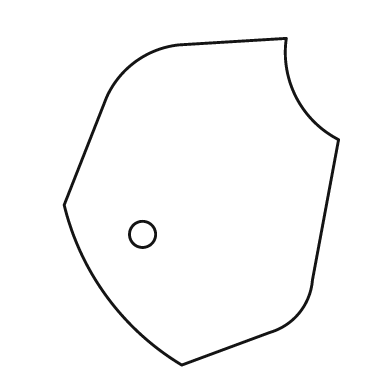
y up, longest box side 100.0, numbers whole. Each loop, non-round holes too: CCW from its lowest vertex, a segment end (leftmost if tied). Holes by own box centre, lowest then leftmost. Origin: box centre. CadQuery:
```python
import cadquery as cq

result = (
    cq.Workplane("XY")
    .moveTo(-6.0, -50.0)
    .lineTo(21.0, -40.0)
    .threePointArc((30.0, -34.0), (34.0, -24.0))
    .lineTo(42.0, 19.0)
    .threePointArc((29.0, 32.0), (26.0, 50.0))
    .lineTo(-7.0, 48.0)
    .threePointArc((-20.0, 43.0), (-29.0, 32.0))
    .lineTo(-42.0, -1.0)
    .threePointArc((-29.0, -29.0), (-6.0, -50.0))
    .close()
    .moveTo(-18.0, -10.0)
    .circle(4.0)
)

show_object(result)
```